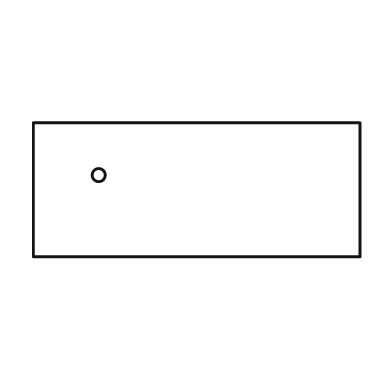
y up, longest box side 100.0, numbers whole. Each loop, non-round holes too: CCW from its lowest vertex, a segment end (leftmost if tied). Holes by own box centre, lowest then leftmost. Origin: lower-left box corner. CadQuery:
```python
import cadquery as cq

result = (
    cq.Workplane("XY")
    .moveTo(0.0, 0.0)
    .lineTo(100.0, 0.0)
    .lineTo(100.0, 41.0)
    .lineTo(0.0, 41.0)
    .close()
    .moveTo(20.0, 25.0)
    .circle(2.0)
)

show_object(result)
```